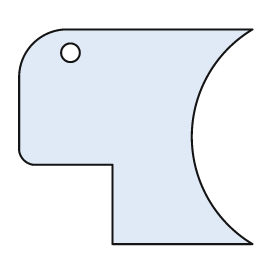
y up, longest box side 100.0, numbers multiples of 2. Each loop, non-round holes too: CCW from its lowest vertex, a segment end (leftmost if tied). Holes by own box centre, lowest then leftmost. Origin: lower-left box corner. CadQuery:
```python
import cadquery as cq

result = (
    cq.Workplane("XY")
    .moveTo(40.0, 0.0)
    .lineTo(100.0, 0.0)
    .threePointArc((74.0, 46.0), (100.0, 92.0))
    .lineTo(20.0, 92.0)
    .threePointArc((6.0, 86.0), (0.0, 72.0))
    .lineTo(0.0, 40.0)
    .threePointArc((2.0, 36.0), (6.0, 34.0))
    .lineTo(40.0, 34.0)
    .close()
    .moveTo(22.0, 82.0)
    .circle(4.0)
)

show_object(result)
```